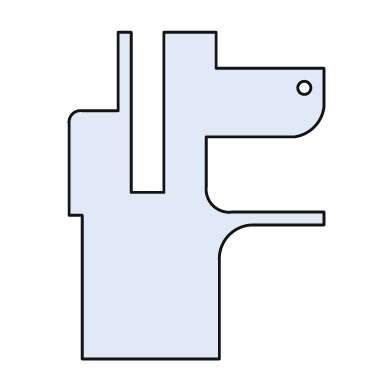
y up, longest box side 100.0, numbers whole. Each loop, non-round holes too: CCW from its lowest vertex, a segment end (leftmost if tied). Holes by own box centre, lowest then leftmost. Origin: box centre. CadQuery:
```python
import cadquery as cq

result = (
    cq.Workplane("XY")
    .moveTo(-35.0, -50.0)
    .lineTo(7.0, -50.0)
    .lineTo(7.0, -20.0)
    .threePointArc((10.0, -12.0), (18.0, -9.0))
    .lineTo(39.0, -9.0)
    .lineTo(39.0, -5.0)
    .lineTo(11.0, -5.0)
    .threePointArc((5.0, -3.0), (3.0, 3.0))
    .lineTo(3.0, 18.0)
    .lineTo(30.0, 18.0)
    .threePointArc((36.0, 21.0), (39.0, 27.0))
    .lineTo(39.0, 39.0)
    .lineTo(6.0, 39.0)
    .lineTo(6.0, 50.0)
    .lineTo(-10.0, 50.0)
    .lineTo(-10.0, 1.0)
    .lineTo(-20.0, 1.0)
    .lineTo(-20.0, 50.0)
    .lineTo(-24.0, 50.0)
    .lineTo(-24.0, 26.0)
    .lineTo(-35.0, 26.0)
    .threePointArc((-38.0, 25.0), (-39.0, 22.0))
    .lineTo(-39.0, -6.0)
    .lineTo(-35.0, -6.0)
    .close()
    .moveTo(33.0, 33.0)
    .circle(2.0)
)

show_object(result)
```